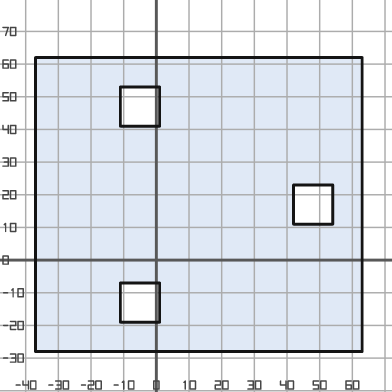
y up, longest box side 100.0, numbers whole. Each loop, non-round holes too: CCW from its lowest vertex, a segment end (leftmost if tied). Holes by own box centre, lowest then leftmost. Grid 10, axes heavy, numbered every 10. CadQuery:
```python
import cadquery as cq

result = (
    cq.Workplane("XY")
    .moveTo(-37.0, -28.0)
    .lineTo(63.0, -28.0)
    .lineTo(63.0, 62.0)
    .lineTo(-37.0, 62.0)
    .close()
    .moveTo(-11.0, -19.0)
    .lineTo(1.0, -19.0)
    .lineTo(1.0, -7.0)
    .lineTo(-11.0, -7.0)
    .close()
    .moveTo(42.0, 11.0)
    .lineTo(54.0, 11.0)
    .lineTo(54.0, 23.0)
    .lineTo(42.0, 23.0)
    .close()
    .moveTo(-11.0, 41.0)
    .lineTo(1.0, 41.0)
    .lineTo(1.0, 53.0)
    .lineTo(-11.0, 53.0)
    .close()
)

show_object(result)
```